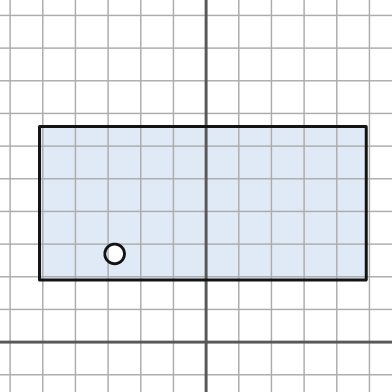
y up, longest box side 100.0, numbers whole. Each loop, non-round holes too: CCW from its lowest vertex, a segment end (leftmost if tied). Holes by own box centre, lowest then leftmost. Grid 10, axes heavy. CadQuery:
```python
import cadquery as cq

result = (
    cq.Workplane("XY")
    .moveTo(-51.0, 19.0)
    .lineTo(49.0, 19.0)
    .lineTo(49.0, 66.0)
    .lineTo(-51.0, 66.0)
    .close()
    .moveTo(-28.0, 27.0)
    .circle(3.0)
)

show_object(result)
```